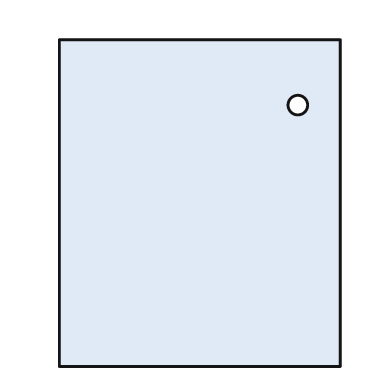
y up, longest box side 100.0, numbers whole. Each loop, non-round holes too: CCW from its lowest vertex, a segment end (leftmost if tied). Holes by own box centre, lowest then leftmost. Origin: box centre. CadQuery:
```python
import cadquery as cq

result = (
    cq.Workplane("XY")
    .moveTo(-43.0, -50.0)
    .lineTo(43.0, -50.0)
    .lineTo(43.0, 50.0)
    .lineTo(-43.0, 50.0)
    .close()
    .moveTo(30.0, 30.0)
    .circle(3.0)
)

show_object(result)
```